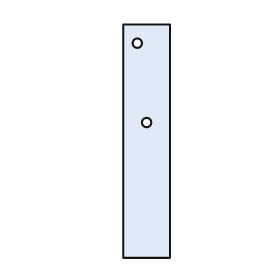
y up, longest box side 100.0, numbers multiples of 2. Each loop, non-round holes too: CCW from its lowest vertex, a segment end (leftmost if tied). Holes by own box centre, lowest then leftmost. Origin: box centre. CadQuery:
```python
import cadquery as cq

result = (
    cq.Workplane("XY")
    .moveTo(-10.0, -50.0)
    .lineTo(10.0, -50.0)
    .lineTo(10.0, 50.0)
    .lineTo(-10.0, 50.0)
    .close()
    .moveTo(0.0, 8.0)
    .circle(2.0)
    .moveTo(-4.0, 42.0)
    .circle(2.0)
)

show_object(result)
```